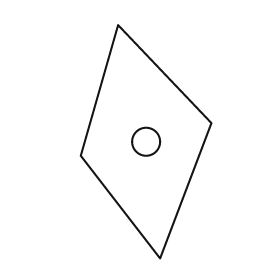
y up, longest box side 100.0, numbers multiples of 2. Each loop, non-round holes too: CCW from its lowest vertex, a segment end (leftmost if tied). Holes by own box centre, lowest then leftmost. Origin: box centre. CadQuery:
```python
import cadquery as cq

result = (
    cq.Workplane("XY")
    .moveTo(6.0, -50.0)
    .lineTo(28.0, 8.0)
    .lineTo(-12.0, 50.0)
    .lineTo(-28.0, -6.0)
    .close()
    .moveTo(0.0, 0.0)
    .circle(6.0)
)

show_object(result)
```